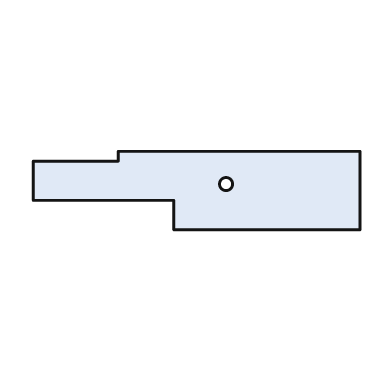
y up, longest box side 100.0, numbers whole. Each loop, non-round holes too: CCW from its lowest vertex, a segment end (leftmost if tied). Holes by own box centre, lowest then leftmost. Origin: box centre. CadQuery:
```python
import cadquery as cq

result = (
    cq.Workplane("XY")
    .moveTo(-7.0, -12.0)
    .lineTo(50.0, -12.0)
    .lineTo(50.0, 12.0)
    .lineTo(-24.0, 12.0)
    .lineTo(-24.0, 9.0)
    .lineTo(-50.0, 9.0)
    .lineTo(-50.0, -3.0)
    .lineTo(-7.0, -3.0)
    .close()
    .moveTo(9.0, 2.0)
    .circle(2.0)
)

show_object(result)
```